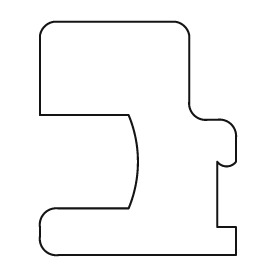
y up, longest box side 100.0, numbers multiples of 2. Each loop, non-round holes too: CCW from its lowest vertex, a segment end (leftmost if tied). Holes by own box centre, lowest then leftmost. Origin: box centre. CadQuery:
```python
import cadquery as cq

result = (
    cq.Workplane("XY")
    .moveTo(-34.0, -50.0)
    .lineTo(42.0, -50.0)
    .lineTo(42.0, -38.0)
    .lineTo(34.0, -38.0)
    .lineTo(34.0, -10.0)
    .threePointArc((38.0, -12.0), (42.0, -10.0))
    .lineTo(42.0, 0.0)
    .threePointArc((40.0, 6.0), (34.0, 8.0))
    .lineTo(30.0, 8.0)
    .threePointArc((24.0, 10.0), (22.0, 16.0))
    .lineTo(22.0, 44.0)
    .threePointArc((20.0, 48.0), (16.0, 50.0))
    .lineTo(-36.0, 50.0)
    .threePointArc((-40.0, 48.0), (-42.0, 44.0))
    .lineTo(-42.0, 10.0)
    .lineTo(-4.0, 10.0)
    .threePointArc((0.0, -10.0), (-4.0, -30.0))
    .lineTo(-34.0, -30.0)
    .threePointArc((-40.0, -32.0), (-42.0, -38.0))
    .lineTo(-42.0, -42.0)
    .threePointArc((-40.0, -48.0), (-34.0, -50.0))
    .close()
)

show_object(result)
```